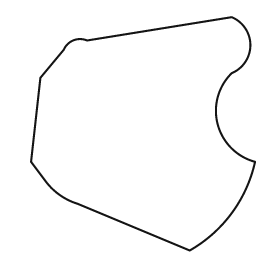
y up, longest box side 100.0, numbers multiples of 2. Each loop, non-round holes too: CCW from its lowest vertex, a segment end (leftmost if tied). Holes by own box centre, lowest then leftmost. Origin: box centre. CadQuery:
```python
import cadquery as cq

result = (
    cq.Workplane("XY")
    .moveTo(20.0, -50.0)
    .threePointArc((38.0, -34.0), (48.0, -12.0))
    .threePointArc((32.0, 4.0), (38.0, 26.0))
    .threePointArc((46.0, 38.0), (38.0, 50.0))
    .lineTo(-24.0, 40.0)
    .threePointArc((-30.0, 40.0), (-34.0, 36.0))
    .lineTo(-44.0, 24.0)
    .lineTo(-48.0, -12.0)
    .lineTo(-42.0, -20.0)
    .threePointArc((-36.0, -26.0), (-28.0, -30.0))
    .close()
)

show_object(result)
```